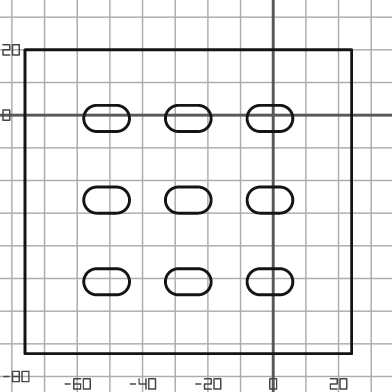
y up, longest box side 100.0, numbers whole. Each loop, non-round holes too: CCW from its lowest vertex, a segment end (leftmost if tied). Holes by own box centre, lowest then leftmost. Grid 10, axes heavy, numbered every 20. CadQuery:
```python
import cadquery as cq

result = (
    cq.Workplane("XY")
    .moveTo(-76.0, -73.0)
    .lineTo(24.0, -73.0)
    .lineTo(24.0, 20.0)
    .lineTo(-76.0, 20.0)
    .close()
    .moveTo(-54.0, -55.0)
    .lineTo(-48.0, -55.0)
    .threePointArc((-44.0, -51.0), (-48.0, -47.0))
    .lineTo(-54.0, -47.0)
    .threePointArc((-58.0, -51.0), (-54.0, -55.0))
    .close()
    .moveTo(-29.0, -55.0)
    .lineTo(-23.0, -55.0)
    .threePointArc((-19.0, -51.0), (-23.0, -47.0))
    .lineTo(-29.0, -47.0)
    .threePointArc((-33.0, -51.0), (-29.0, -55.0))
    .close()
    .moveTo(-4.0, -55.0)
    .lineTo(2.0, -55.0)
    .threePointArc((6.0, -51.0), (2.0, -47.0))
    .lineTo(-4.0, -47.0)
    .threePointArc((-8.0, -51.0), (-4.0, -55.0))
    .close()
    .moveTo(-54.0, -30.0)
    .lineTo(-48.0, -30.0)
    .threePointArc((-44.0, -26.0), (-48.0, -22.0))
    .lineTo(-54.0, -22.0)
    .threePointArc((-58.0, -26.0), (-54.0, -30.0))
    .close()
    .moveTo(-29.0, -30.0)
    .lineTo(-23.0, -30.0)
    .threePointArc((-19.0, -26.0), (-23.0, -22.0))
    .lineTo(-29.0, -22.0)
    .threePointArc((-33.0, -26.0), (-29.0, -30.0))
    .close()
    .moveTo(-4.0, -30.0)
    .lineTo(2.0, -30.0)
    .threePointArc((6.0, -26.0), (2.0, -22.0))
    .lineTo(-4.0, -22.0)
    .threePointArc((-8.0, -26.0), (-4.0, -30.0))
    .close()
    .moveTo(-54.0, -5.0)
    .lineTo(-48.0, -5.0)
    .threePointArc((-44.0, -1.0), (-48.0, 3.0))
    .lineTo(-54.0, 3.0)
    .threePointArc((-58.0, -1.0), (-54.0, -5.0))
    .close()
    .moveTo(-29.0, -5.0)
    .lineTo(-23.0, -5.0)
    .threePointArc((-19.0, -1.0), (-23.0, 3.0))
    .lineTo(-29.0, 3.0)
    .threePointArc((-33.0, -1.0), (-29.0, -5.0))
    .close()
    .moveTo(-4.0, -5.0)
    .lineTo(2.0, -5.0)
    .threePointArc((6.0, -1.0), (2.0, 3.0))
    .lineTo(-4.0, 3.0)
    .threePointArc((-8.0, -1.0), (-4.0, -5.0))
    .close()
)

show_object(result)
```